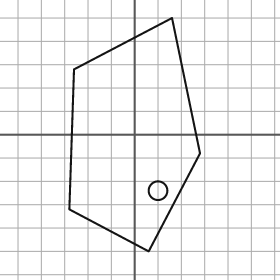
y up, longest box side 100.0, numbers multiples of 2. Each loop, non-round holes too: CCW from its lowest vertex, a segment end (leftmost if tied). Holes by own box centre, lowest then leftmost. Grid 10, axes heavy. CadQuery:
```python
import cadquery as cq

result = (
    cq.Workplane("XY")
    .moveTo(6.0, -50.0)
    .lineTo(28.0, -8.0)
    .lineTo(16.0, 50.0)
    .lineTo(-26.0, 28.0)
    .lineTo(-28.0, -32.0)
    .close()
    .moveTo(10.0, -24.0)
    .circle(4.0)
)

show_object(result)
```